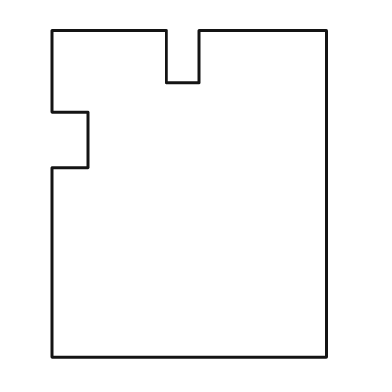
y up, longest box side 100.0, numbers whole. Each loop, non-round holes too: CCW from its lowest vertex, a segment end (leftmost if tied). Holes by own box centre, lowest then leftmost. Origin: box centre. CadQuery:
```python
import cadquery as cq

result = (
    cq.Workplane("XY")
    .moveTo(-42.0, -50.0)
    .lineTo(42.0, -50.0)
    .lineTo(42.0, 50.0)
    .lineTo(3.0, 50.0)
    .lineTo(3.0, 34.0)
    .lineTo(-7.0, 34.0)
    .lineTo(-7.0, 50.0)
    .lineTo(-42.0, 50.0)
    .lineTo(-42.0, 25.0)
    .lineTo(-31.0, 25.0)
    .lineTo(-31.0, 8.0)
    .lineTo(-42.0, 8.0)
    .close()
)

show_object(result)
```